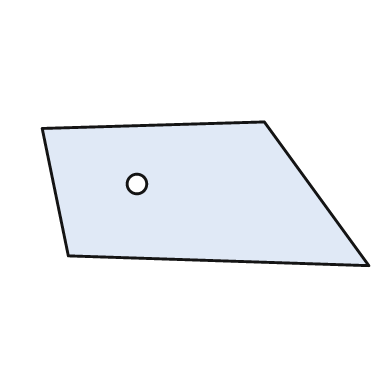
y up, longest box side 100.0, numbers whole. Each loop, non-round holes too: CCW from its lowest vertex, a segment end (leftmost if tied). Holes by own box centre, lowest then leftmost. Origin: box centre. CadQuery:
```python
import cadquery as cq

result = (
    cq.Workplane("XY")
    .moveTo(50.0, -22.0)
    .lineTo(18.0, 22.0)
    .lineTo(-50.0, 20.0)
    .lineTo(-42.0, -19.0)
    .close()
    .moveTo(-21.0, 3.0)
    .circle(3.0)
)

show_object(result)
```